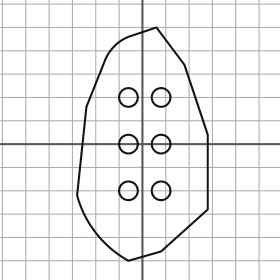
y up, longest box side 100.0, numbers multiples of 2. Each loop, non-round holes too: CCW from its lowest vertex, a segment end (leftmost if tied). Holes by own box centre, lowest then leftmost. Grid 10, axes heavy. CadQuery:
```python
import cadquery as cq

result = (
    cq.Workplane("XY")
    .moveTo(-6.0, -50.0)
    .lineTo(8.0, -46.0)
    .lineTo(28.0, -28.0)
    .lineTo(28.0, 4.0)
    .lineTo(18.0, 34.0)
    .lineTo(6.0, 50.0)
    .lineTo(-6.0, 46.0)
    .threePointArc((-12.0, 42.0), (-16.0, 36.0))
    .lineTo(-24.0, 16.0)
    .lineTo(-28.0, -22.0)
    .threePointArc((-20.0, -38.0), (-6.0, -50.0))
    .close()
    .moveTo(-6.0, -20.0)
    .circle(4.0)
    .moveTo(8.0, -20.0)
    .circle(4.0)
    .moveTo(-6.0, 0.0)
    .circle(4.0)
    .moveTo(8.0, 0.0)
    .circle(4.0)
    .moveTo(-6.0, 20.0)
    .circle(4.0)
    .moveTo(8.0, 20.0)
    .circle(4.0)
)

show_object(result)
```